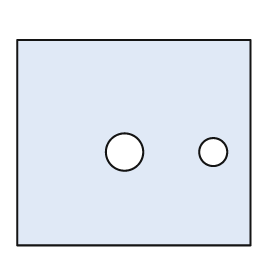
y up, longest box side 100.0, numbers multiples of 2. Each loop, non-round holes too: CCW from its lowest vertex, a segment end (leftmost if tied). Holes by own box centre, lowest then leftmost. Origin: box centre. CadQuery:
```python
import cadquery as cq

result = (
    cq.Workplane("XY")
    .moveTo(-50.0, -44.0)
    .lineTo(50.0, -44.0)
    .lineTo(50.0, 44.0)
    .lineTo(-50.0, 44.0)
    .close()
    .moveTo(-4.0, -4.0)
    .circle(8.0)
    .moveTo(34.0, -4.0)
    .circle(6.0)
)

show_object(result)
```